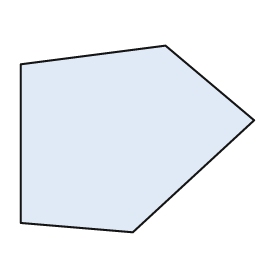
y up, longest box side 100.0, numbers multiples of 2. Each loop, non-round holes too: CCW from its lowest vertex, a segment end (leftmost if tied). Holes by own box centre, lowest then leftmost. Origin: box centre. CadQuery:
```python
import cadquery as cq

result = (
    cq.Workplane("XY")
    .moveTo(-2.0, -40.0)
    .lineTo(50.0, 8.0)
    .lineTo(12.0, 40.0)
    .lineTo(-50.0, 32.0)
    .lineTo(-50.0, -36.0)
    .close()
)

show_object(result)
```